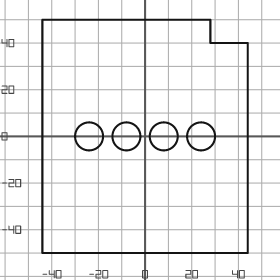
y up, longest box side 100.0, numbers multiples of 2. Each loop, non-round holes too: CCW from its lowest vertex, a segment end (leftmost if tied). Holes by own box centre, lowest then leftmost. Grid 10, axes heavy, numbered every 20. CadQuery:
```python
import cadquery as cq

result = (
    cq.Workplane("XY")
    .moveTo(-44.0, -50.0)
    .lineTo(44.0, -50.0)
    .lineTo(44.0, 40.0)
    .lineTo(28.0, 40.0)
    .lineTo(28.0, 50.0)
    .lineTo(-44.0, 50.0)
    .close()
    .moveTo(-24.0, 0.0)
    .circle(6.0)
    .moveTo(-8.0, 0.0)
    .circle(6.0)
    .moveTo(8.0, 0.0)
    .circle(6.0)
    .moveTo(24.0, 0.0)
    .circle(6.0)
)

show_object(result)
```